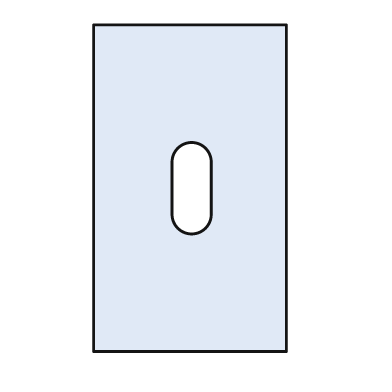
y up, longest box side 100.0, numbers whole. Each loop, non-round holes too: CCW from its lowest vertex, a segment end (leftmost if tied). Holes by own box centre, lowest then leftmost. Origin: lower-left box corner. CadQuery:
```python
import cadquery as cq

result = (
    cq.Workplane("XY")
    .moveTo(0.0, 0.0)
    .lineTo(59.0, 0.0)
    .lineTo(59.0, 100.0)
    .lineTo(0.0, 100.0)
    .close()
    .moveTo(24.0, 42.0)
    .threePointArc((30.0, 36.0), (36.0, 42.0))
    .lineTo(36.0, 58.0)
    .threePointArc((30.0, 64.0), (24.0, 58.0))
    .close()
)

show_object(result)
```